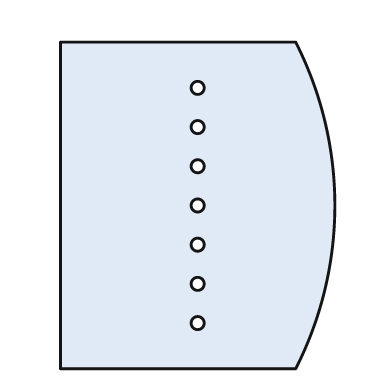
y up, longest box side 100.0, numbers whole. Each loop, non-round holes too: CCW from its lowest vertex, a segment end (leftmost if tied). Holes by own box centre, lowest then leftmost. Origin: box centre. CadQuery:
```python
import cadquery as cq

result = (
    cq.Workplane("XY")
    .moveTo(-42.0, -50.0)
    .lineTo(30.0, -50.0)
    .threePointArc((42.0, 0.0), (30.0, 50.0))
    .lineTo(-42.0, 50.0)
    .close()
    .moveTo(0.0, -36.0)
    .circle(2.0)
    .moveTo(0.0, -24.0)
    .circle(2.0)
    .moveTo(0.0, -12.0)
    .circle(2.0)
    .moveTo(0.0, 0.0)
    .circle(2.0)
    .moveTo(0.0, 12.0)
    .circle(2.0)
    .moveTo(0.0, 24.0)
    .circle(2.0)
    .moveTo(0.0, 36.0)
    .circle(2.0)
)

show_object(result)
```